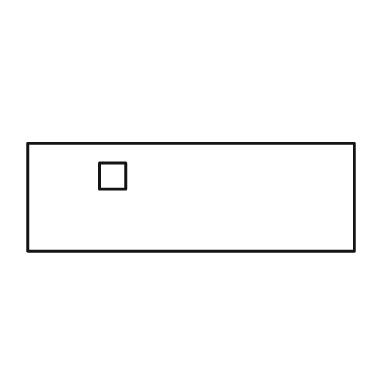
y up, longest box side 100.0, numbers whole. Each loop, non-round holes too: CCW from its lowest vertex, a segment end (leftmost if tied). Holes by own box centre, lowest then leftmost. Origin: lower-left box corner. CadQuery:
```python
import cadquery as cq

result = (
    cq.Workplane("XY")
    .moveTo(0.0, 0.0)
    .lineTo(100.0, 0.0)
    .lineTo(100.0, 33.0)
    .lineTo(0.0, 33.0)
    .close()
    .moveTo(22.0, 19.0)
    .lineTo(30.0, 19.0)
    .lineTo(30.0, 27.0)
    .lineTo(22.0, 27.0)
    .close()
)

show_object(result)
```